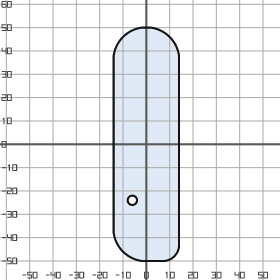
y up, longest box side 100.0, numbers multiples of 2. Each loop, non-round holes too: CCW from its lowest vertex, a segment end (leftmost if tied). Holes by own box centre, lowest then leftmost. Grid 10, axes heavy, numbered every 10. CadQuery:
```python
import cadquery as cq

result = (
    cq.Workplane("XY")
    .moveTo(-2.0, -50.0)
    .lineTo(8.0, -50.0)
    .threePointArc((12.0, -48.0), (14.0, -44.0))
    .lineTo(14.0, 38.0)
    .threePointArc((10.0, 46.0), (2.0, 50.0))
    .lineTo(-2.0, 50.0)
    .threePointArc((-10.0, 46.0), (-14.0, 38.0))
    .lineTo(-14.0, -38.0)
    .threePointArc((-10.0, -46.0), (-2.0, -50.0))
    .close()
    .moveTo(-6.0, -24.0)
    .circle(2.0)
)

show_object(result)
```